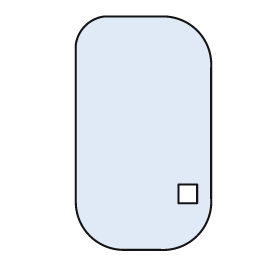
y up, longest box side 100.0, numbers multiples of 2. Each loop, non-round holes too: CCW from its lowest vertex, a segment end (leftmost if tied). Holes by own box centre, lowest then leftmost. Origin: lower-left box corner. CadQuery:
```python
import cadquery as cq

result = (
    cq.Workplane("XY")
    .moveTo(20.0, 0.0)
    .lineTo(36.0, 0.0)
    .threePointArc((52.0, 6.0), (58.0, 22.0))
    .lineTo(58.0, 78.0)
    .threePointArc((52.0, 94.0), (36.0, 100.0))
    .lineTo(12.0, 100.0)
    .threePointArc((4.0, 96.0), (0.0, 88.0))
    .lineTo(0.0, 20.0)
    .threePointArc((6.0, 6.0), (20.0, 0.0))
    .close()
    .moveTo(44.0, 20.0)
    .lineTo(52.0, 20.0)
    .lineTo(52.0, 28.0)
    .lineTo(44.0, 28.0)
    .close()
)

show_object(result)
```